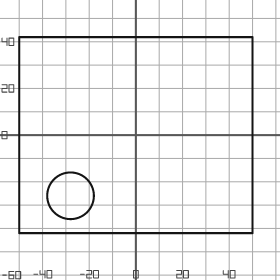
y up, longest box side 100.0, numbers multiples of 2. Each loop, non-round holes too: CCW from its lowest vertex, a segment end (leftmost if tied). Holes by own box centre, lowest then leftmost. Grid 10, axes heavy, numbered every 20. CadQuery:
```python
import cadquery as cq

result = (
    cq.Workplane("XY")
    .moveTo(-50.0, -42.0)
    .lineTo(50.0, -42.0)
    .lineTo(50.0, 42.0)
    .lineTo(-50.0, 42.0)
    .close()
    .moveTo(-28.0, -26.0)
    .circle(10.0)
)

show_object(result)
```